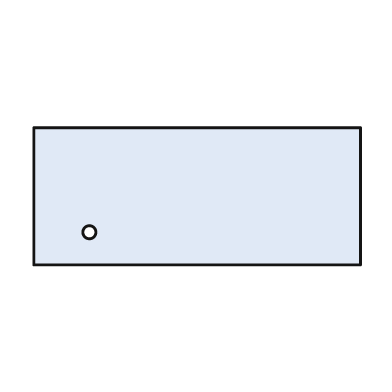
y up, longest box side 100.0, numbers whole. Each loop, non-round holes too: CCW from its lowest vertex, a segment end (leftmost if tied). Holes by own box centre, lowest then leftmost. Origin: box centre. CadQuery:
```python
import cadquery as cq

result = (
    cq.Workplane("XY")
    .moveTo(-50.0, -21.0)
    .lineTo(50.0, -21.0)
    .lineTo(50.0, 21.0)
    .lineTo(-50.0, 21.0)
    .close()
    .moveTo(-33.0, -11.0)
    .circle(2.0)
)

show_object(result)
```